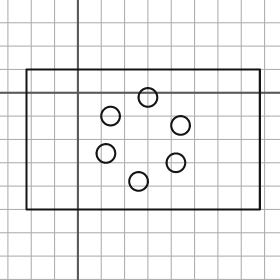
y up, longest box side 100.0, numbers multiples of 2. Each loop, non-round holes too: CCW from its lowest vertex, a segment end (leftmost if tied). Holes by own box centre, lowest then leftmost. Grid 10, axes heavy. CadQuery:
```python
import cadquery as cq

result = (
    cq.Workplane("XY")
    .moveTo(-22.0, -50.0)
    .lineTo(78.0, -50.0)
    .lineTo(78.0, 10.0)
    .lineTo(-22.0, 10.0)
    .close()
    .moveTo(26.0, -38.0)
    .circle(4.0)
    .moveTo(42.0, -30.0)
    .circle(4.0)
    .moveTo(12.0, -26.0)
    .circle(4.0)
    .moveTo(44.0, -14.0)
    .circle(4.0)
    .moveTo(14.0, -10.0)
    .circle(4.0)
    .moveTo(30.0, -2.0)
    .circle(4.0)
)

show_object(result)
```